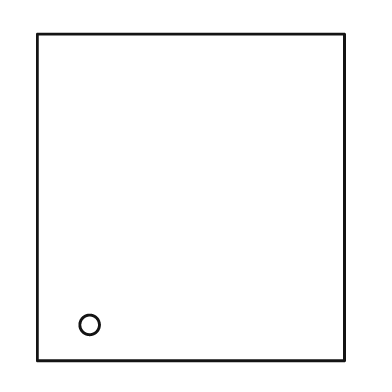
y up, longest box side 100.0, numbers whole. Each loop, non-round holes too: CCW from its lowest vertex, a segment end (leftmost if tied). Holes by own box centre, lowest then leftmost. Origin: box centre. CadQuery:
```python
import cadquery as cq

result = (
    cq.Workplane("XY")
    .moveTo(-47.0, -50.0)
    .lineTo(47.0, -50.0)
    .lineTo(47.0, 50.0)
    .lineTo(-47.0, 50.0)
    .close()
    .moveTo(-31.0, -39.0)
    .circle(3.0)
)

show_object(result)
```